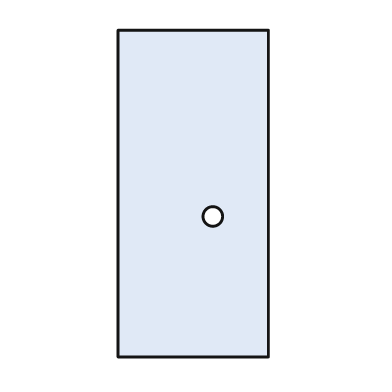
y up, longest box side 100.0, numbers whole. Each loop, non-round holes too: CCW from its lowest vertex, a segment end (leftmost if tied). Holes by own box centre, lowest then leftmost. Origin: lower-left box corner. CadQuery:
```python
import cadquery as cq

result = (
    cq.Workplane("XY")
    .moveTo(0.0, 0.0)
    .lineTo(46.0, 0.0)
    .lineTo(46.0, 100.0)
    .lineTo(0.0, 100.0)
    .close()
    .moveTo(29.0, 43.0)
    .circle(3.0)
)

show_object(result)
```